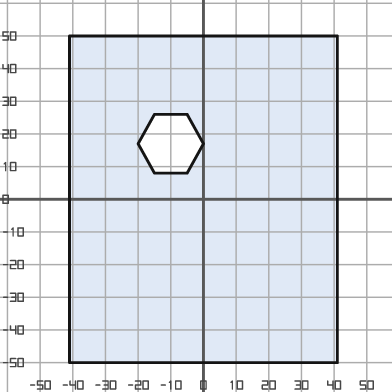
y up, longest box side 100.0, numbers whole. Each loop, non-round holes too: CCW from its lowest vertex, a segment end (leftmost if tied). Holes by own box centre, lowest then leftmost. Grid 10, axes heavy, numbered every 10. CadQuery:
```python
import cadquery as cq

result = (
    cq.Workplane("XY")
    .moveTo(-41.0, -50.0)
    .lineTo(41.0, -50.0)
    .lineTo(41.0, 50.0)
    .lineTo(-41.0, 50.0)
    .close()
    .moveTo(-15.0, 8.0)
    .lineTo(-5.0, 8.0)
    .lineTo(0.0, 17.0)
    .lineTo(-5.0, 26.0)
    .lineTo(-15.0, 26.0)
    .lineTo(-20.0, 17.0)
    .close()
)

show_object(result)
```